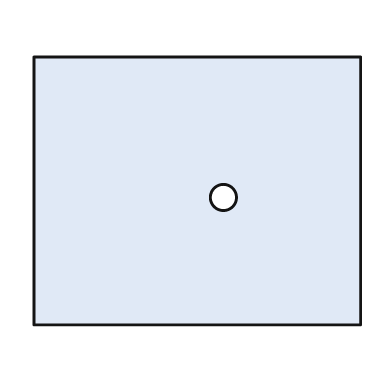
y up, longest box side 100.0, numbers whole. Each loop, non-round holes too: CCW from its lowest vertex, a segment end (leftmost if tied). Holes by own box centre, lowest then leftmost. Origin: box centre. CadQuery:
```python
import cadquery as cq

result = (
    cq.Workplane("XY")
    .moveTo(-50.0, -41.0)
    .lineTo(50.0, -41.0)
    .lineTo(50.0, 41.0)
    .lineTo(-50.0, 41.0)
    .close()
    .moveTo(8.0, -2.0)
    .circle(4.0)
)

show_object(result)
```